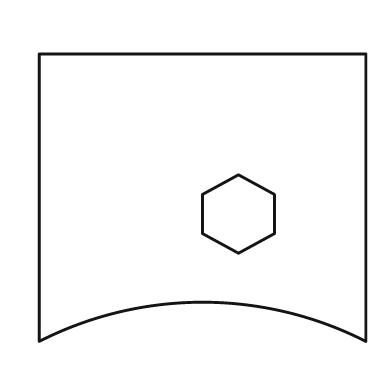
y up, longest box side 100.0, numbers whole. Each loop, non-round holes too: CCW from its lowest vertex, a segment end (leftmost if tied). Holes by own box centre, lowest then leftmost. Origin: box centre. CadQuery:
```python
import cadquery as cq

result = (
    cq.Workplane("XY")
    .moveTo(-50.0, -44.0)
    .threePointArc((0.0, -32.0), (50.0, -44.0))
    .lineTo(50.0, 44.0)
    .lineTo(-50.0, 44.0)
    .close()
    .moveTo(11.0, -17.0)
    .lineTo(22.0, -11.0)
    .lineTo(22.0, 1.0)
    .lineTo(11.0, 7.0)
    .lineTo(0.0, 1.0)
    .lineTo(0.0, -11.0)
    .close()
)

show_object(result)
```